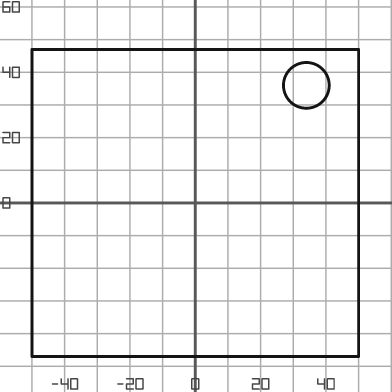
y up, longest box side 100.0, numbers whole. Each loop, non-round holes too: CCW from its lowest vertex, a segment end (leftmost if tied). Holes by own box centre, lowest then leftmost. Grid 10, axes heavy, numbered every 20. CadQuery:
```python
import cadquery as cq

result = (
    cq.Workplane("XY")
    .moveTo(-50.0, -47.0)
    .lineTo(50.0, -47.0)
    .lineTo(50.0, 47.0)
    .lineTo(-50.0, 47.0)
    .close()
    .moveTo(34.0, 36.0)
    .circle(7.0)
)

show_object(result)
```